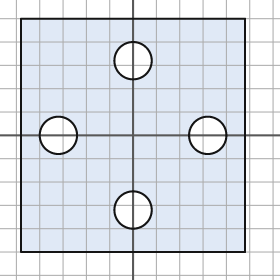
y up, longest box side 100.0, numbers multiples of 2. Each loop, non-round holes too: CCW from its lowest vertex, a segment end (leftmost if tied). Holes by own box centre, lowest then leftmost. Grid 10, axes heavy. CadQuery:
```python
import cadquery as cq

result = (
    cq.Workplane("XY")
    .moveTo(-48.0, -50.0)
    .lineTo(48.0, -50.0)
    .lineTo(48.0, 50.0)
    .lineTo(-48.0, 50.0)
    .close()
    .moveTo(0.0, -32.0)
    .circle(8.0)
    .moveTo(-32.0, 0.0)
    .circle(8.0)
    .moveTo(32.0, 0.0)
    .circle(8.0)
    .moveTo(0.0, 32.0)
    .circle(8.0)
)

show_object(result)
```